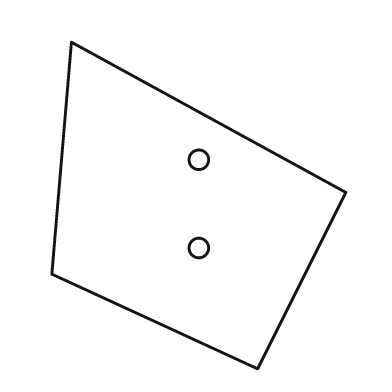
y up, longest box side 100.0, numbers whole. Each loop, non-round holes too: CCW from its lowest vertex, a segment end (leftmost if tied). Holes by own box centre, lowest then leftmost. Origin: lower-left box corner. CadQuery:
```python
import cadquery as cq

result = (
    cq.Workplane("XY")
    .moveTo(63.0, 0.0)
    .lineTo(90.0, 54.0)
    .lineTo(6.0, 100.0)
    .lineTo(0.0, 29.0)
    .close()
    .moveTo(45.0, 37.0)
    .circle(3.0)
    .moveTo(45.0, 64.0)
    .circle(3.0)
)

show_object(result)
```